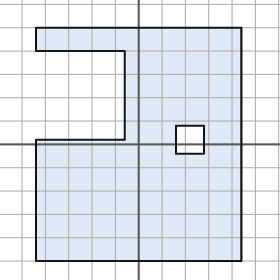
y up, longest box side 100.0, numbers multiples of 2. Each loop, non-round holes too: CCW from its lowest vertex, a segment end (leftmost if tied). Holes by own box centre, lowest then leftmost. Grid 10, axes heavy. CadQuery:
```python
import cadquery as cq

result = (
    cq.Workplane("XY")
    .moveTo(-44.0, -50.0)
    .lineTo(44.0, -50.0)
    .lineTo(44.0, 50.0)
    .lineTo(-44.0, 50.0)
    .lineTo(-44.0, 40.0)
    .lineTo(-6.0, 40.0)
    .lineTo(-6.0, 2.0)
    .lineTo(-44.0, 2.0)
    .close()
    .moveTo(16.0, -4.0)
    .lineTo(28.0, -4.0)
    .lineTo(28.0, 8.0)
    .lineTo(16.0, 8.0)
    .close()
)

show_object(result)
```